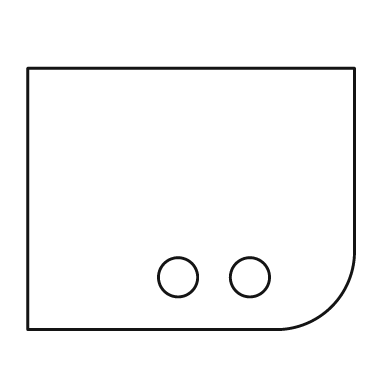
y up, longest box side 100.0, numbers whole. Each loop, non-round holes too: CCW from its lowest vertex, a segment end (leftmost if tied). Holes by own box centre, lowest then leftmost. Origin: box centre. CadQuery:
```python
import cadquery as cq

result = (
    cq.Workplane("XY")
    .moveTo(-50.0, -40.0)
    .lineTo(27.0, -40.0)
    .threePointArc((43.0, -33.0), (50.0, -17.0))
    .lineTo(50.0, 40.0)
    .lineTo(-50.0, 40.0)
    .close()
    .moveTo(-4.0, -24.0)
    .circle(6.0)
    .moveTo(18.0, -24.0)
    .circle(6.0)
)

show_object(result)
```